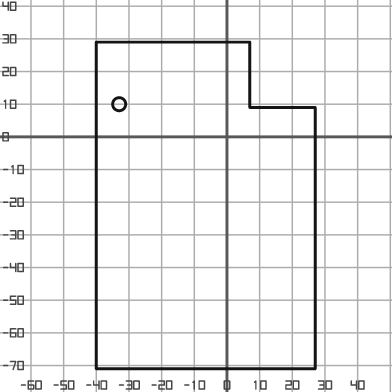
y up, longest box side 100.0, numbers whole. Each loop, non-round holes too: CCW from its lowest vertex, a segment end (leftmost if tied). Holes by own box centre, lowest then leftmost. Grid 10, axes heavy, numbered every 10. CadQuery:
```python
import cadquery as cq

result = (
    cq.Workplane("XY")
    .moveTo(-40.0, -71.0)
    .lineTo(27.0, -71.0)
    .lineTo(27.0, 9.0)
    .lineTo(7.0, 9.0)
    .lineTo(7.0, 29.0)
    .lineTo(-40.0, 29.0)
    .close()
    .moveTo(-33.0, 10.0)
    .circle(2.0)
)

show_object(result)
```